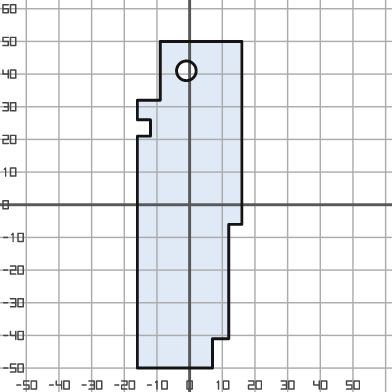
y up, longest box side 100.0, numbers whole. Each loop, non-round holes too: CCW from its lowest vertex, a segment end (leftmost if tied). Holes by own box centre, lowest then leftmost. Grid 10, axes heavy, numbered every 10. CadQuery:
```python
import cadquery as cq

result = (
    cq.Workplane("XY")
    .moveTo(-16.0, -50.0)
    .lineTo(7.0, -50.0)
    .lineTo(7.0, -41.0)
    .lineTo(12.0, -41.0)
    .lineTo(12.0, -6.0)
    .lineTo(16.0, -6.0)
    .lineTo(16.0, 50.0)
    .lineTo(-9.0, 50.0)
    .lineTo(-9.0, 32.0)
    .lineTo(-16.0, 32.0)
    .lineTo(-16.0, 26.0)
    .lineTo(-12.0, 26.0)
    .lineTo(-12.0, 21.0)
    .lineTo(-16.0, 21.0)
    .close()
    .moveTo(-1.0, 41.0)
    .circle(3.0)
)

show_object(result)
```